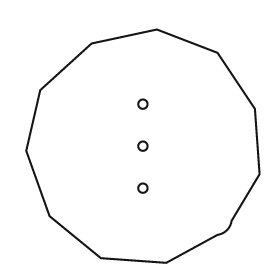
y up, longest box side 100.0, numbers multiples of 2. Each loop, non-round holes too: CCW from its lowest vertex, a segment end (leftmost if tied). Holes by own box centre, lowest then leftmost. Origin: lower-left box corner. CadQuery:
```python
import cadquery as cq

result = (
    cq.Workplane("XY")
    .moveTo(60.0, 0.0)
    .lineTo(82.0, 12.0)
    .threePointArc((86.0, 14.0), (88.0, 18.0))
    .lineTo(100.0, 38.0)
    .lineTo(98.0, 66.0)
    .lineTo(82.0, 90.0)
    .lineTo(56.0, 100.0)
    .lineTo(28.0, 94.0)
    .lineTo(6.0, 74.0)
    .lineTo(0.0, 48.0)
    .lineTo(10.0, 20.0)
    .lineTo(32.0, 2.0)
    .close()
    .moveTo(50.0, 32.0)
    .circle(2.0)
    .moveTo(50.0, 50.0)
    .circle(2.0)
    .moveTo(50.0, 68.0)
    .circle(2.0)
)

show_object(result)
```